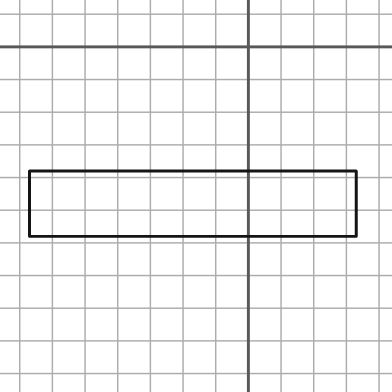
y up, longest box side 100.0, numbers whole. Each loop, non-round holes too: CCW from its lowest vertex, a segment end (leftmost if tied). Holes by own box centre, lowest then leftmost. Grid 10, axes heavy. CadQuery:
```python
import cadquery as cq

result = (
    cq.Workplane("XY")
    .moveTo(-67.0, -58.0)
    .lineTo(33.0, -58.0)
    .lineTo(33.0, -38.0)
    .lineTo(-67.0, -38.0)
    .close()
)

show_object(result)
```